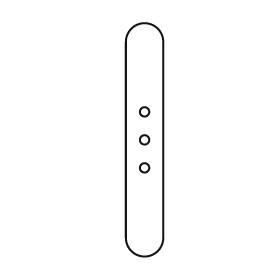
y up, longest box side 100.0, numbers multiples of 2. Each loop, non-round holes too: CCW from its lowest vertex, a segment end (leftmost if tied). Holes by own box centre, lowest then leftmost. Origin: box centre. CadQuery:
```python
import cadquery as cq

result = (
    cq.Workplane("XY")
    .moveTo(-8.0, -42.0)
    .threePointArc((0.0, -50.0), (8.0, -42.0))
    .lineTo(8.0, 42.0)
    .threePointArc((0.0, 50.0), (-8.0, 42.0))
    .close()
    .moveTo(0.0, -12.0)
    .circle(2.0)
    .moveTo(0.0, 0.0)
    .circle(2.0)
    .moveTo(0.0, 12.0)
    .circle(2.0)
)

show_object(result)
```